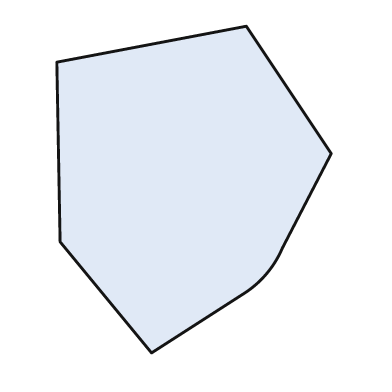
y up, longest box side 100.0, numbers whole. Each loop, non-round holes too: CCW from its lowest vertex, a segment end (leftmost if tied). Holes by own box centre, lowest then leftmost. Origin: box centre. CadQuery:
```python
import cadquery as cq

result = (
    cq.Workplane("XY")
    .moveTo(-13.0, -50.0)
    .lineTo(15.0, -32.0)
    .threePointArc((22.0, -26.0), (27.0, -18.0))
    .lineTo(42.0, 11.0)
    .lineTo(16.0, 50.0)
    .lineTo(-42.0, 39.0)
    .lineTo(-41.0, -16.0)
    .close()
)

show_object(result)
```